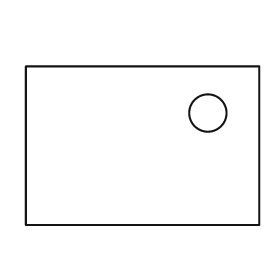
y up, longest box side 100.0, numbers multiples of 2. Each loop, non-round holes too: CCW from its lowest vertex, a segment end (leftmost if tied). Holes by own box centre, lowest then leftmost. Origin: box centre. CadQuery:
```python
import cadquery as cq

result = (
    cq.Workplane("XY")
    .moveTo(-50.0, -34.0)
    .lineTo(50.0, -34.0)
    .lineTo(50.0, 34.0)
    .lineTo(-50.0, 34.0)
    .close()
    .moveTo(28.0, 14.0)
    .circle(8.0)
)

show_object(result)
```